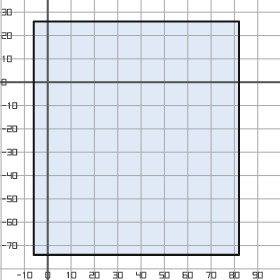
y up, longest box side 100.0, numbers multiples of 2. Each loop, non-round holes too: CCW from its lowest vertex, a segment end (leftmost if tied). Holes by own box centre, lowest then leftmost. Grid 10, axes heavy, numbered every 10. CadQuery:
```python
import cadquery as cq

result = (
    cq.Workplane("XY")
    .moveTo(-6.0, -74.0)
    .lineTo(82.0, -74.0)
    .lineTo(82.0, 26.0)
    .lineTo(-6.0, 26.0)
    .close()
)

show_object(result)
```